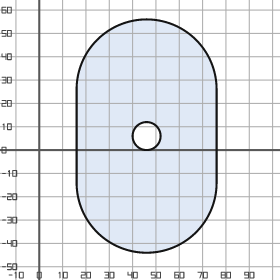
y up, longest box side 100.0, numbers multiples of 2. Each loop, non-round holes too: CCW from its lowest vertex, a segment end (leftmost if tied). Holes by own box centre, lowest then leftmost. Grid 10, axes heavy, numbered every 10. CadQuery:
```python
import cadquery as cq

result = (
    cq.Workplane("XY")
    .moveTo(16.0, -14.0)
    .threePointArc((46.0, -44.0), (76.0, -14.0))
    .lineTo(76.0, 26.0)
    .threePointArc((46.0, 56.0), (16.0, 26.0))
    .close()
    .moveTo(46.0, 6.0)
    .circle(6.0)
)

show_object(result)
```